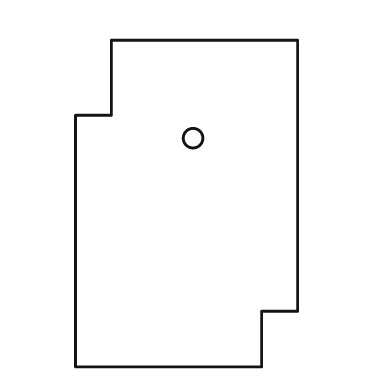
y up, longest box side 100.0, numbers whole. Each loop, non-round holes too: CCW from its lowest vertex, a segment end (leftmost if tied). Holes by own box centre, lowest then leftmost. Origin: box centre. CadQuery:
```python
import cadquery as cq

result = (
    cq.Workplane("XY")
    .moveTo(-34.0, -50.0)
    .lineTo(23.0, -50.0)
    .lineTo(23.0, -33.0)
    .lineTo(34.0, -33.0)
    .lineTo(34.0, 50.0)
    .lineTo(-23.0, 50.0)
    .lineTo(-23.0, 27.0)
    .lineTo(-34.0, 27.0)
    .close()
    .moveTo(2.0, 20.0)
    .circle(3.0)
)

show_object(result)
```